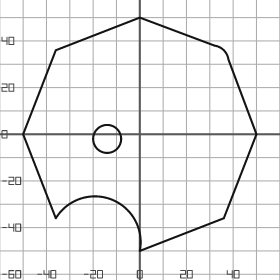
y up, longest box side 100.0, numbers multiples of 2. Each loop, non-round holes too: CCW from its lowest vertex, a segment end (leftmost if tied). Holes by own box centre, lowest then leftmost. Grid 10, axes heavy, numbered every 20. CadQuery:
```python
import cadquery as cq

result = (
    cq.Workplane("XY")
    .moveTo(0.0, -50.0)
    .lineTo(36.0, -36.0)
    .lineTo(50.0, 0.0)
    .lineTo(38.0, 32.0)
    .threePointArc((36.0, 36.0), (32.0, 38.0))
    .lineTo(0.0, 50.0)
    .lineTo(-36.0, 36.0)
    .lineTo(-50.0, 0.0)
    .lineTo(-36.0, -36.0)
    .threePointArc((-12.0, -28.0), (0.0, -50.0))
    .close()
    .moveTo(-14.0, -2.0)
    .circle(6.0)
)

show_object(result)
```